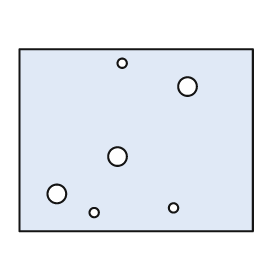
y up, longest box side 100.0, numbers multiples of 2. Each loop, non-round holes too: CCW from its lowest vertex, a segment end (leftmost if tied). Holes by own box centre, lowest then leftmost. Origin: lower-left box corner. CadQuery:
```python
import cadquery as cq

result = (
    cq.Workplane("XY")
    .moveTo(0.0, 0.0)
    .lineTo(100.0, 0.0)
    .lineTo(100.0, 78.0)
    .lineTo(0.0, 78.0)
    .close()
    .moveTo(32.0, 8.0)
    .circle(2.0)
    .moveTo(66.0, 10.0)
    .circle(2.0)
    .moveTo(16.0, 16.0)
    .circle(4.0)
    .moveTo(42.0, 32.0)
    .circle(4.0)
    .moveTo(72.0, 62.0)
    .circle(4.0)
    .moveTo(44.0, 72.0)
    .circle(2.0)
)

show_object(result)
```